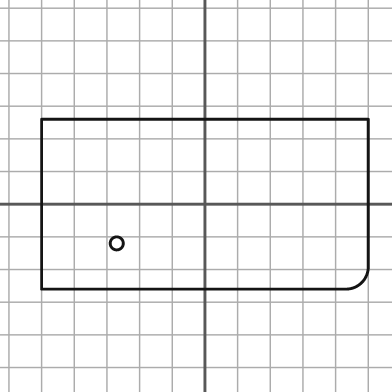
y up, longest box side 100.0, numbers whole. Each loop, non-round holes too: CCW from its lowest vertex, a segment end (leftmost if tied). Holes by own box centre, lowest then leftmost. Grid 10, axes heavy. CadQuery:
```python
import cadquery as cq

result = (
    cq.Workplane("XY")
    .moveTo(-50.0, -26.0)
    .lineTo(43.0, -26.0)
    .threePointArc((48.0, -24.0), (50.0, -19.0))
    .lineTo(50.0, 26.0)
    .lineTo(-50.0, 26.0)
    .close()
    .moveTo(-27.0, -12.0)
    .circle(2.0)
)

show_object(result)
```